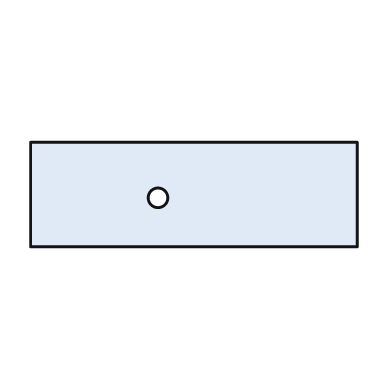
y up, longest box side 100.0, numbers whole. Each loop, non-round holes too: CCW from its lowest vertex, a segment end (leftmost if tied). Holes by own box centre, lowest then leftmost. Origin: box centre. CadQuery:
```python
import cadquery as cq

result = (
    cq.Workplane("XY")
    .moveTo(-50.0, -16.0)
    .lineTo(50.0, -16.0)
    .lineTo(50.0, 16.0)
    .lineTo(-50.0, 16.0)
    .close()
    .moveTo(-11.0, -1.0)
    .circle(3.0)
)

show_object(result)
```